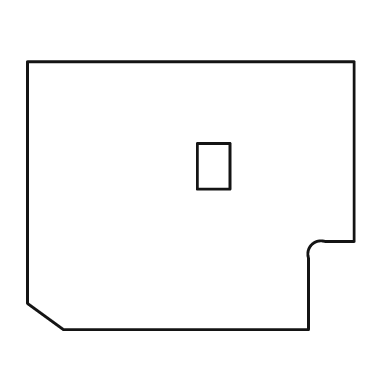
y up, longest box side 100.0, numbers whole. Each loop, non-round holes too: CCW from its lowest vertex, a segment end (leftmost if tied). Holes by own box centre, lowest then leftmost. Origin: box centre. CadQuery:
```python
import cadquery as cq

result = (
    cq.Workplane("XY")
    .moveTo(-39.0, -41.0)
    .lineTo(36.0, -41.0)
    .lineTo(36.0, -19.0)
    .threePointArc((37.0, -15.0), (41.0, -14.0))
    .lineTo(50.0, -14.0)
    .lineTo(50.0, 41.0)
    .lineTo(-50.0, 41.0)
    .lineTo(-50.0, -33.0)
    .close()
    .moveTo(2.0, 2.0)
    .lineTo(12.0, 2.0)
    .lineTo(12.0, 16.0)
    .lineTo(2.0, 16.0)
    .close()
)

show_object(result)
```